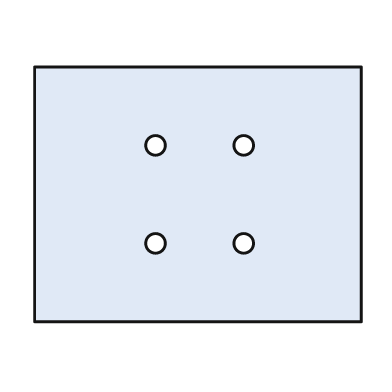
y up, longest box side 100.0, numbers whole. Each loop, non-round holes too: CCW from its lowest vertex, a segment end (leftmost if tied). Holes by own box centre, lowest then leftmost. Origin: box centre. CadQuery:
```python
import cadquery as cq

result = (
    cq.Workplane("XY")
    .moveTo(-50.0, -39.0)
    .lineTo(50.0, -39.0)
    .lineTo(50.0, 39.0)
    .lineTo(-50.0, 39.0)
    .close()
    .moveTo(-13.0, -15.0)
    .circle(3.0)
    .moveTo(14.0, -15.0)
    .circle(3.0)
    .moveTo(-13.0, 15.0)
    .circle(3.0)
    .moveTo(14.0, 15.0)
    .circle(3.0)
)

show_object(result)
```